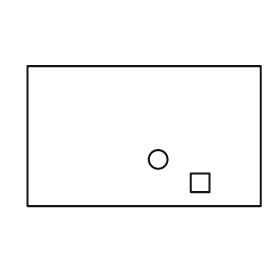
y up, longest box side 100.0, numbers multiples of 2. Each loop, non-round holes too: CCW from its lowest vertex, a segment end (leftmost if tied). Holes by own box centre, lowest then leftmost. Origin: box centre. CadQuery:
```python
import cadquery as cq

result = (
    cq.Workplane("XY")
    .moveTo(-50.0, -30.0)
    .lineTo(50.0, -30.0)
    .lineTo(50.0, 30.0)
    .lineTo(-50.0, 30.0)
    .close()
    .moveTo(20.0, -24.0)
    .lineTo(28.0, -24.0)
    .lineTo(28.0, -16.0)
    .lineTo(20.0, -16.0)
    .close()
    .moveTo(6.0, -10.0)
    .circle(4.0)
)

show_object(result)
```